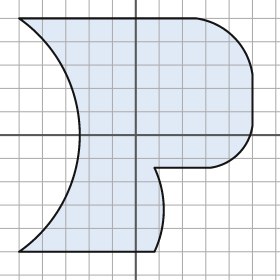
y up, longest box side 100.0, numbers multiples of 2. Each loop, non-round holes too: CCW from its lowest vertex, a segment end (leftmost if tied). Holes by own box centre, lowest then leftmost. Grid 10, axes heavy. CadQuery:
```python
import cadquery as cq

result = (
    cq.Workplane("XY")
    .moveTo(-50.0, -50.0)
    .lineTo(8.0, -50.0)
    .threePointArc((12.0, -32.0), (8.0, -14.0))
    .lineTo(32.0, -14.0)
    .threePointArc((44.0, -8.0), (50.0, 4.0))
    .lineTo(50.0, 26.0)
    .threePointArc((42.0, 42.0), (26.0, 50.0))
    .lineTo(-50.0, 50.0)
    .threePointArc((-24.0, 0.0), (-50.0, -50.0))
    .close()
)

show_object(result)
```